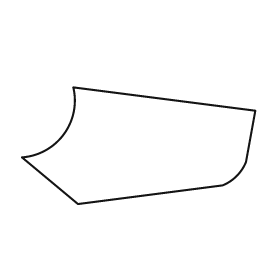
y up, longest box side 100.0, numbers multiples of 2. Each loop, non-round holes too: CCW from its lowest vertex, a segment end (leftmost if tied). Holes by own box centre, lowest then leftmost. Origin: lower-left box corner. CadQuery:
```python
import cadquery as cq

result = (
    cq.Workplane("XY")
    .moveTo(24.0, 0.0)
    .lineTo(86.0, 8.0)
    .threePointArc((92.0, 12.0), (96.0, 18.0))
    .lineTo(100.0, 40.0)
    .lineTo(22.0, 50.0)
    .threePointArc((18.0, 30.0), (0.0, 20.0))
    .close()
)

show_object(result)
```